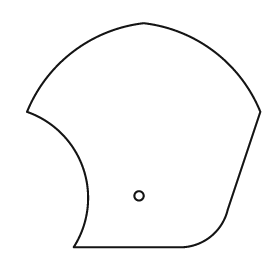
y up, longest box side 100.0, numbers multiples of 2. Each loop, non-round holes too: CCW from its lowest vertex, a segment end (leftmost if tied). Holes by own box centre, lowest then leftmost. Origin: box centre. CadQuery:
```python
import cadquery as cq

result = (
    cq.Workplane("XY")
    .moveTo(-30.0, -48.0)
    .lineTo(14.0, -48.0)
    .threePointArc((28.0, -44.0), (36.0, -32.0))
    .lineTo(50.0, 10.0)
    .threePointArc((30.0, 36.0), (0.0, 48.0))
    .threePointArc((-30.0, 36.0), (-50.0, 10.0))
    .threePointArc((-26.0, -14.0), (-30.0, -48.0))
    .close()
    .moveTo(-2.0, -26.0)
    .circle(2.0)
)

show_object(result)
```